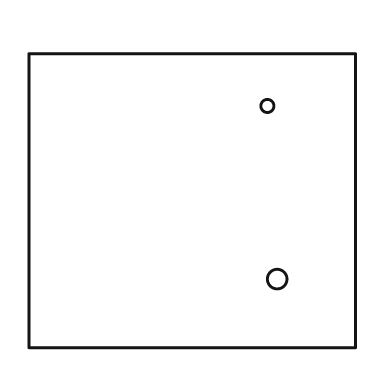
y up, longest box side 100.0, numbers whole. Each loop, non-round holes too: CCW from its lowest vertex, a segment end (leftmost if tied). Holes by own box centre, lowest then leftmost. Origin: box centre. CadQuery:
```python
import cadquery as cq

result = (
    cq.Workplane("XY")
    .moveTo(-50.0, -45.0)
    .lineTo(50.0, -45.0)
    .lineTo(50.0, 45.0)
    .lineTo(-50.0, 45.0)
    .close()
    .moveTo(26.0, -24.0)
    .circle(3.0)
    .moveTo(23.0, 29.0)
    .circle(2.0)
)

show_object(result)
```